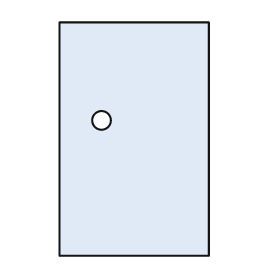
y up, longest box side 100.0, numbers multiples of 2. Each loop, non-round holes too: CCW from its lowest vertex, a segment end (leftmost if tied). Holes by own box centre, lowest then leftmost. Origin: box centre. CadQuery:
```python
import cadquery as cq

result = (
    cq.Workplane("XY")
    .moveTo(-32.0, -50.0)
    .lineTo(32.0, -50.0)
    .lineTo(32.0, 50.0)
    .lineTo(-32.0, 50.0)
    .close()
    .moveTo(-14.0, 8.0)
    .circle(4.0)
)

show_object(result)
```